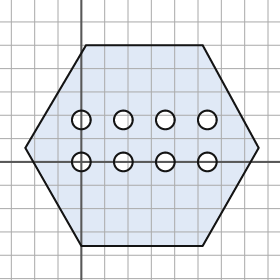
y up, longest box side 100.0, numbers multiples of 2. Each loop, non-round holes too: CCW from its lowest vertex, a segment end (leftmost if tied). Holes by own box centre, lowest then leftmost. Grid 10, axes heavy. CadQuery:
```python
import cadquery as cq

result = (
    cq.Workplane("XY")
    .moveTo(0.0, -36.0)
    .lineTo(52.0, -36.0)
    .lineTo(76.0, 6.0)
    .lineTo(52.0, 50.0)
    .lineTo(2.0, 50.0)
    .lineTo(-24.0, 6.0)
    .close()
    .moveTo(0.0, 0.0)
    .circle(4.0)
    .moveTo(18.0, 0.0)
    .circle(4.0)
    .moveTo(36.0, 0.0)
    .circle(4.0)
    .moveTo(54.0, 0.0)
    .circle(4.0)
    .moveTo(0.0, 18.0)
    .circle(4.0)
    .moveTo(18.0, 18.0)
    .circle(4.0)
    .moveTo(36.0, 18.0)
    .circle(4.0)
    .moveTo(54.0, 18.0)
    .circle(4.0)
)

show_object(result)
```